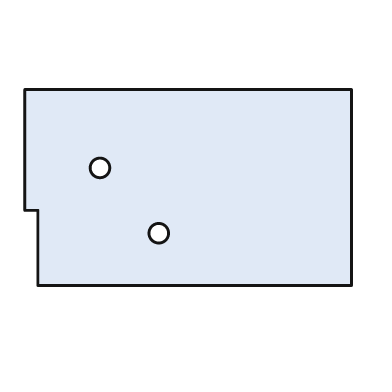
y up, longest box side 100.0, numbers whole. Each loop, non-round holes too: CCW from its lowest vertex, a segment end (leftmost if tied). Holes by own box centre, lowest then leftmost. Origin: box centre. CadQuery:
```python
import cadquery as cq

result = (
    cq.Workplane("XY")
    .moveTo(-46.0, -30.0)
    .lineTo(50.0, -30.0)
    .lineTo(50.0, 30.0)
    .lineTo(-50.0, 30.0)
    .lineTo(-50.0, -7.0)
    .lineTo(-46.0, -7.0)
    .close()
    .moveTo(-9.0, -14.0)
    .circle(3.0)
    .moveTo(-27.0, 6.0)
    .circle(3.0)
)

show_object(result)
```